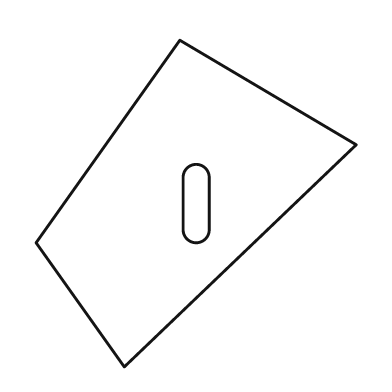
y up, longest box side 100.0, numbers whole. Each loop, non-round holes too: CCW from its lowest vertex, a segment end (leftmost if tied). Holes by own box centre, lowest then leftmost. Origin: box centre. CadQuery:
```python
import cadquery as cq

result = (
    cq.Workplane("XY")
    .moveTo(-22.0, -50.0)
    .lineTo(49.0, 18.0)
    .lineTo(-5.0, 50.0)
    .lineTo(-49.0, -12.0)
    .close()
    .moveTo(-4.0, -8.0)
    .threePointArc((0.0, -12.0), (4.0, -8.0))
    .lineTo(4.0, 8.0)
    .threePointArc((0.0, 12.0), (-4.0, 8.0))
    .close()
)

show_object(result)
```